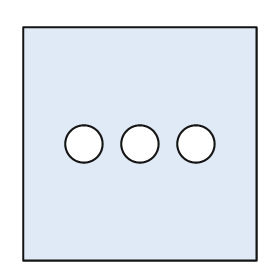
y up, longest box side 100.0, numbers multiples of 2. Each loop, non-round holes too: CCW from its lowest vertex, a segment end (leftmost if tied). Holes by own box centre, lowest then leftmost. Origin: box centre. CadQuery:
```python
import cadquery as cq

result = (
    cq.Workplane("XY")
    .moveTo(-50.0, -50.0)
    .lineTo(50.0, -50.0)
    .lineTo(50.0, 50.0)
    .lineTo(-50.0, 50.0)
    .close()
    .moveTo(-24.0, 0.0)
    .circle(8.0)
    .moveTo(0.0, 0.0)
    .circle(8.0)
    .moveTo(24.0, 0.0)
    .circle(8.0)
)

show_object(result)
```